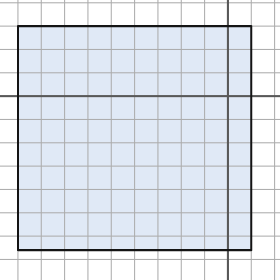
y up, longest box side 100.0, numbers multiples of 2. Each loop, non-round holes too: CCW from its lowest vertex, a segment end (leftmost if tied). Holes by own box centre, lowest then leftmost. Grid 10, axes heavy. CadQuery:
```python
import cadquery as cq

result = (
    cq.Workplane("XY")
    .moveTo(-90.0, -66.0)
    .lineTo(10.0, -66.0)
    .lineTo(10.0, 30.0)
    .lineTo(-90.0, 30.0)
    .close()
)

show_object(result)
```